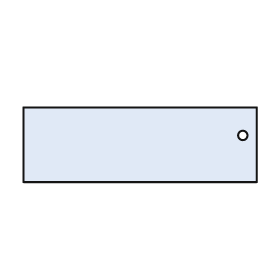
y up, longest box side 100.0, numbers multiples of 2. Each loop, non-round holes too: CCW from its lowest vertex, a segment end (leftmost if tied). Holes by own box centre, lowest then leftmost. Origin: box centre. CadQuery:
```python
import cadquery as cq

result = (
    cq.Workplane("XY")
    .moveTo(-50.0, -16.0)
    .lineTo(50.0, -16.0)
    .lineTo(50.0, 16.0)
    .lineTo(-50.0, 16.0)
    .close()
    .moveTo(44.0, 4.0)
    .circle(2.0)
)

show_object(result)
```